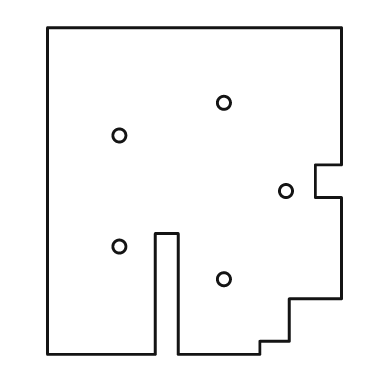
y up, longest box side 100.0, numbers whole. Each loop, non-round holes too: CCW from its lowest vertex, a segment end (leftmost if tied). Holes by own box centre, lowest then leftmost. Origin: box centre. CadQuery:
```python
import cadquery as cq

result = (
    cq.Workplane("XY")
    .moveTo(-45.0, -50.0)
    .lineTo(-12.0, -50.0)
    .lineTo(-12.0, -13.0)
    .lineTo(-5.0, -13.0)
    .lineTo(-5.0, -50.0)
    .lineTo(20.0, -50.0)
    .lineTo(20.0, -46.0)
    .lineTo(29.0, -46.0)
    .lineTo(29.0, -33.0)
    .lineTo(45.0, -33.0)
    .lineTo(45.0, -2.0)
    .lineTo(37.0, -2.0)
    .lineTo(37.0, 8.0)
    .lineTo(45.0, 8.0)
    .lineTo(45.0, 50.0)
    .lineTo(-45.0, 50.0)
    .close()
    .moveTo(9.0, -27.0)
    .circle(2.0)
    .moveTo(-23.0, -17.0)
    .circle(2.0)
    .moveTo(28.0, 0.0)
    .circle(2.0)
    .moveTo(-23.0, 17.0)
    .circle(2.0)
    .moveTo(9.0, 27.0)
    .circle(2.0)
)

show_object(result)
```